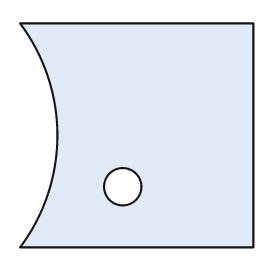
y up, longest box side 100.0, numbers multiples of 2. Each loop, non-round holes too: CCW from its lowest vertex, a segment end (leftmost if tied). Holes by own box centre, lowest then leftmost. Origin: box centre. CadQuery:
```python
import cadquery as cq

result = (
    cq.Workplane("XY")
    .moveTo(-50.0, -48.0)
    .lineTo(50.0, -48.0)
    .lineTo(50.0, 48.0)
    .lineTo(-50.0, 48.0)
    .threePointArc((-34.0, 0.0), (-50.0, -48.0))
    .close()
    .moveTo(-6.0, -22.0)
    .circle(8.0)
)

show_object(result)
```